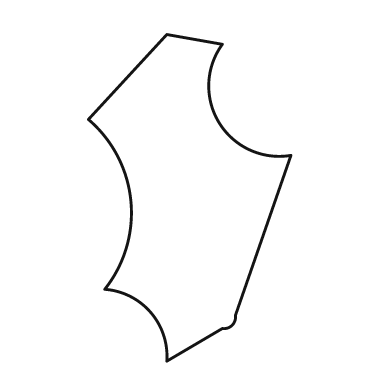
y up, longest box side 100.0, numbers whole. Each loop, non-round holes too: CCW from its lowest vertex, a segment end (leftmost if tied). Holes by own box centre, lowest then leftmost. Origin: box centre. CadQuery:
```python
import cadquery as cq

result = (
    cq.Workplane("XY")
    .moveTo(-7.0, -50.0)
    .lineTo(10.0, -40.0)
    .threePointArc((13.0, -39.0), (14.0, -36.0))
    .lineTo(31.0, 13.0)
    .threePointArc((9.0, 23.0), (10.0, 47.0))
    .lineTo(-7.0, 50.0)
    .lineTo(-31.0, 24.0)
    .threePointArc((-18.0, -1.0), (-26.0, -28.0))
    .threePointArc((-12.0, -35.0), (-7.0, -50.0))
    .close()
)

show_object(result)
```